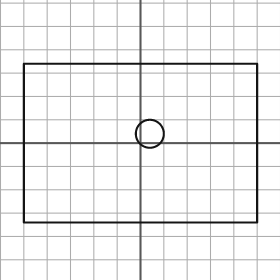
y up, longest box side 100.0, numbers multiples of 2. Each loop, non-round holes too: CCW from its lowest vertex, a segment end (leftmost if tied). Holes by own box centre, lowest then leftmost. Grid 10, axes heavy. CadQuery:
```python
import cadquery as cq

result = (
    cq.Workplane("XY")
    .moveTo(-50.0, -34.0)
    .lineTo(50.0, -34.0)
    .lineTo(50.0, 34.0)
    .lineTo(-50.0, 34.0)
    .close()
    .moveTo(4.0, 4.0)
    .circle(6.0)
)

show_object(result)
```